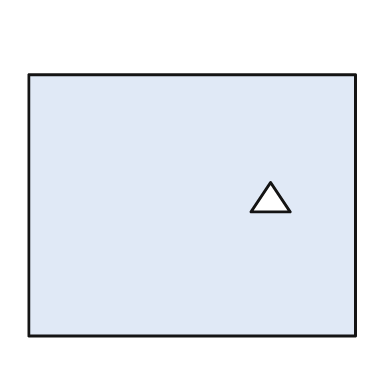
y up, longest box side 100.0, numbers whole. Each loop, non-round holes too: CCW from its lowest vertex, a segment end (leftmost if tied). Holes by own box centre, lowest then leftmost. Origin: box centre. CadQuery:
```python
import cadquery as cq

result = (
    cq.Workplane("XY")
    .moveTo(-50.0, -40.0)
    .lineTo(50.0, -40.0)
    .lineTo(50.0, 40.0)
    .lineTo(-50.0, 40.0)
    .close()
    .moveTo(18.0, -2.0)
    .lineTo(30.0, -2.0)
    .lineTo(24.0, 7.0)
    .close()
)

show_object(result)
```